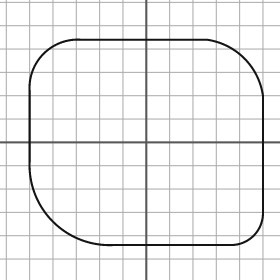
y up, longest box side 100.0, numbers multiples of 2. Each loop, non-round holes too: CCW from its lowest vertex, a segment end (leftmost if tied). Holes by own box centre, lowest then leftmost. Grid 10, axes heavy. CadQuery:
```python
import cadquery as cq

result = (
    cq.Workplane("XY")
    .moveTo(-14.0, -44.0)
    .lineTo(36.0, -44.0)
    .threePointArc((46.0, -40.0), (50.0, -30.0))
    .lineTo(50.0, 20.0)
    .threePointArc((42.0, 36.0), (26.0, 44.0))
    .lineTo(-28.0, 44.0)
    .threePointArc((-44.0, 38.0), (-50.0, 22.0))
    .lineTo(-50.0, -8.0)
    .threePointArc((-40.0, -34.0), (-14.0, -44.0))
    .close()
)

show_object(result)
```